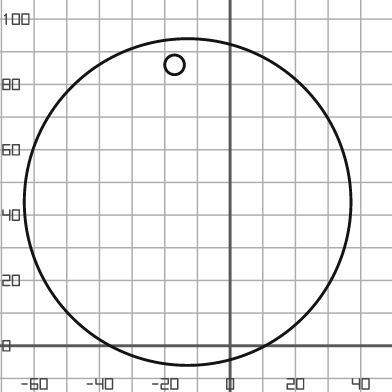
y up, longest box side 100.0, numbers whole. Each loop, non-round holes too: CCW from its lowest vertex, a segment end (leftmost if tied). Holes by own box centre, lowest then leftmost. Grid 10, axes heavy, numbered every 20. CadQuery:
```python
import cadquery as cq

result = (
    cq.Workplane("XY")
    .moveTo(-13.0, 44.0)
    .circle(50.0)
    .moveTo(-17.0, 86.0)
    .circle(3.0)
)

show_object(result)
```